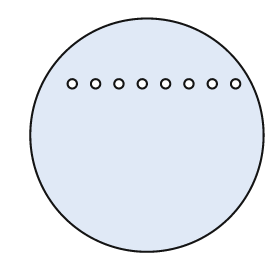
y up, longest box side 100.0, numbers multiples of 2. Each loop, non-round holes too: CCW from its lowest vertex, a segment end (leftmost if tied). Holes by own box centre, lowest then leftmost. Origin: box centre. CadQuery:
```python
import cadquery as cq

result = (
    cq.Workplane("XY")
    .moveTo(0.0, 0.0)
    .circle(50.0)
    .moveTo(-32.0, 22.0)
    .circle(2.0)
    .moveTo(-22.0, 22.0)
    .circle(2.0)
    .moveTo(-12.0, 22.0)
    .circle(2.0)
    .moveTo(-2.0, 22.0)
    .circle(2.0)
    .moveTo(8.0, 22.0)
    .circle(2.0)
    .moveTo(18.0, 22.0)
    .circle(2.0)
    .moveTo(28.0, 22.0)
    .circle(2.0)
    .moveTo(38.0, 22.0)
    .circle(2.0)
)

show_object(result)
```